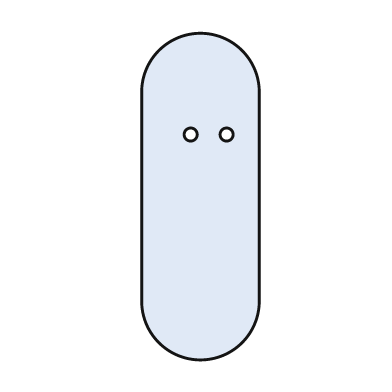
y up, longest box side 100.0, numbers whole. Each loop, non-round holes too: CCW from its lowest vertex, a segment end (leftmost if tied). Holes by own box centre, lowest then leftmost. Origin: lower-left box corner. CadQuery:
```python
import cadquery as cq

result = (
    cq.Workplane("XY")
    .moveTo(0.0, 18.0)
    .threePointArc((18.0, 0.0), (36.0, 18.0))
    .lineTo(36.0, 82.0)
    .threePointArc((18.0, 100.0), (0.0, 82.0))
    .close()
    .moveTo(15.0, 69.0)
    .circle(2.0)
    .moveTo(26.0, 69.0)
    .circle(2.0)
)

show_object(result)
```